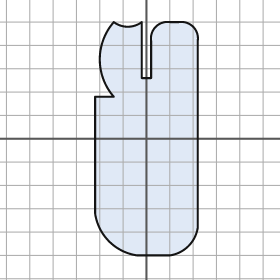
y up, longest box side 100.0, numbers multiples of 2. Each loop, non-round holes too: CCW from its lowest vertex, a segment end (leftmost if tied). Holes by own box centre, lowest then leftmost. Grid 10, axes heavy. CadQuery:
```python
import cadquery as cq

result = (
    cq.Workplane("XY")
    .moveTo(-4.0, -50.0)
    .lineTo(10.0, -50.0)
    .threePointArc((18.0, -46.0), (22.0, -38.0))
    .lineTo(22.0, 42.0)
    .threePointArc((20.0, 48.0), (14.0, 50.0))
    .lineTo(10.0, 50.0)
    .threePointArc((4.0, 48.0), (2.0, 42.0))
    .lineTo(2.0, 26.0)
    .lineTo(-2.0, 26.0)
    .lineTo(-2.0, 50.0)
    .threePointArc((-8.0, 48.0), (-14.0, 50.0))
    .threePointArc((-20.0, 34.0), (-14.0, 18.0))
    .lineTo(-22.0, 18.0)
    .lineTo(-22.0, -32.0)
    .threePointArc((-16.0, -44.0), (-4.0, -50.0))
    .close()
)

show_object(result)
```